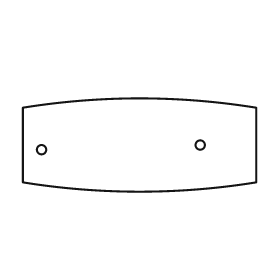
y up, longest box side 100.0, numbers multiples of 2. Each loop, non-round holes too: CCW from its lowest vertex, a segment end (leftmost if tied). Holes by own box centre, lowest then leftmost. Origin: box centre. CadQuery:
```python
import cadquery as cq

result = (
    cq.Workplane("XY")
    .moveTo(-50.0, -16.0)
    .threePointArc((0.0, -20.0), (50.0, -16.0))
    .lineTo(50.0, 16.0)
    .threePointArc((0.0, 20.0), (-50.0, 16.0))
    .close()
    .moveTo(-42.0, -2.0)
    .circle(2.0)
    .moveTo(26.0, 0.0)
    .circle(2.0)
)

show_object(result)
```